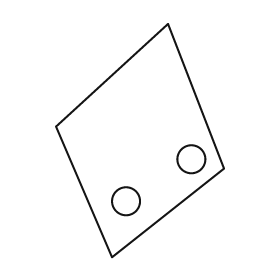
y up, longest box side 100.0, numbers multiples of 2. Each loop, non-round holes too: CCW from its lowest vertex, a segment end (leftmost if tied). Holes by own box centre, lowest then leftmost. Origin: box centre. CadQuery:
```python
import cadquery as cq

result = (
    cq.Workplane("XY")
    .moveTo(-12.0, -50.0)
    .lineTo(36.0, -12.0)
    .lineTo(12.0, 50.0)
    .lineTo(-36.0, 6.0)
    .close()
    .moveTo(-6.0, -26.0)
    .circle(6.0)
    .moveTo(22.0, -8.0)
    .circle(6.0)
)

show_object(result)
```